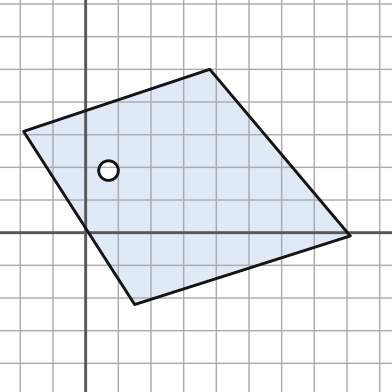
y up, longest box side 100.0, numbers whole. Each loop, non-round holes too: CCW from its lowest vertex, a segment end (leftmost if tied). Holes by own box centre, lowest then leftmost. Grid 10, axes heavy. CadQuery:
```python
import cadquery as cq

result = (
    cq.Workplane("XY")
    .moveTo(15.0, -22.0)
    .lineTo(81.0, -1.0)
    .lineTo(38.0, 50.0)
    .lineTo(-19.0, 31.0)
    .close()
    .moveTo(7.0, 19.0)
    .circle(3.0)
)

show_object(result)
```